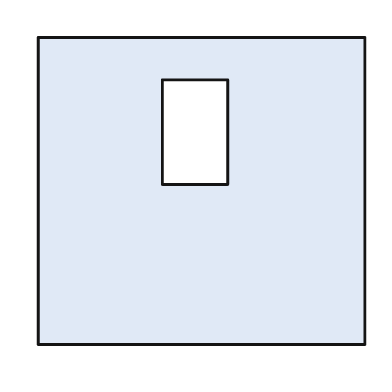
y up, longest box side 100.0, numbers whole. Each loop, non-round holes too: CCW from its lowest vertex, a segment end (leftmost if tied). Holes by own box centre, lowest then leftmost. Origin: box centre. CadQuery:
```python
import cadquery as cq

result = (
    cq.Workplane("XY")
    .moveTo(-50.0, -47.0)
    .lineTo(50.0, -47.0)
    .lineTo(50.0, 47.0)
    .lineTo(-50.0, 47.0)
    .close()
    .moveTo(-12.0, 2.0)
    .lineTo(8.0, 2.0)
    .lineTo(8.0, 34.0)
    .lineTo(-12.0, 34.0)
    .close()
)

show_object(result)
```